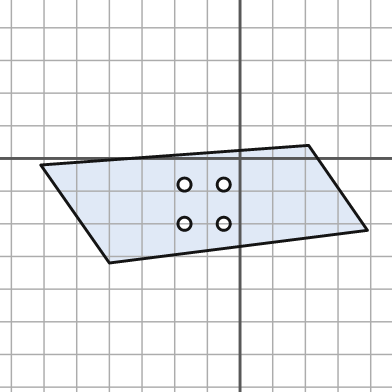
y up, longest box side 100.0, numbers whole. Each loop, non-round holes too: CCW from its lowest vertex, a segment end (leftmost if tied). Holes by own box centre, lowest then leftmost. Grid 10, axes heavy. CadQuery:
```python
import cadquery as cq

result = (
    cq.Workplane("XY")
    .moveTo(-40.0, -32.0)
    .lineTo(39.0, -22.0)
    .lineTo(21.0, 4.0)
    .lineTo(-61.0, -2.0)
    .close()
    .moveTo(-17.0, -20.0)
    .circle(2.0)
    .moveTo(-5.0, -20.0)
    .circle(2.0)
    .moveTo(-17.0, -8.0)
    .circle(2.0)
    .moveTo(-5.0, -8.0)
    .circle(2.0)
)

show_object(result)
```